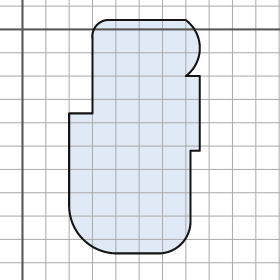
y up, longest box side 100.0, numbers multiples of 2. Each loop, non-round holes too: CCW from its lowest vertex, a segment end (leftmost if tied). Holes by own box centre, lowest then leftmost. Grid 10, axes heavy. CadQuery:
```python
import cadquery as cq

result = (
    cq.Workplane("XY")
    .moveTo(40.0, -96.0)
    .lineTo(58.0, -96.0)
    .threePointArc((68.0, -92.0), (72.0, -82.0))
    .lineTo(72.0, -52.0)
    .lineTo(76.0, -52.0)
    .lineTo(76.0, -20.0)
    .lineTo(70.0, -20.0)
    .threePointArc((76.0, -8.0), (70.0, 4.0))
    .lineTo(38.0, 4.0)
    .threePointArc((32.0, 2.0), (30.0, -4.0))
    .lineTo(30.0, -36.0)
    .lineTo(20.0, -36.0)
    .lineTo(20.0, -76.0)
    .threePointArc((26.0, -90.0), (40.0, -96.0))
    .close()
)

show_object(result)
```